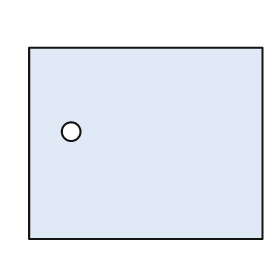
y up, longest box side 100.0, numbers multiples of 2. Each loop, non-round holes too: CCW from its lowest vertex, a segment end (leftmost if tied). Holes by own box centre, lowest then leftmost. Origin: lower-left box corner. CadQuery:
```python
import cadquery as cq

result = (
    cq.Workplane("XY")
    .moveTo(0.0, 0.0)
    .lineTo(100.0, 0.0)
    .lineTo(100.0, 82.0)
    .lineTo(0.0, 82.0)
    .close()
    .moveTo(18.0, 46.0)
    .circle(4.0)
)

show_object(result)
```